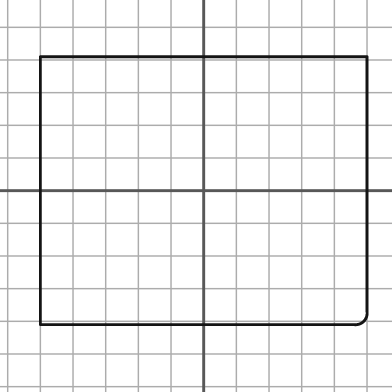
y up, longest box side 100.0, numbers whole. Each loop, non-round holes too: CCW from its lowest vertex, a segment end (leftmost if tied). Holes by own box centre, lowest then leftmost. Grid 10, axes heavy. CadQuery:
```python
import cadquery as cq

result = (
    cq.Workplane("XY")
    .moveTo(-50.0, -41.0)
    .lineTo(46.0, -41.0)
    .threePointArc((49.0, -40.0), (50.0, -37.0))
    .lineTo(50.0, 41.0)
    .lineTo(-50.0, 41.0)
    .close()
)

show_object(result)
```